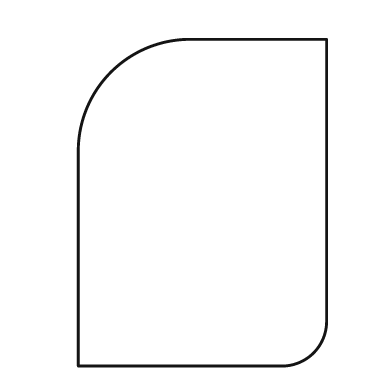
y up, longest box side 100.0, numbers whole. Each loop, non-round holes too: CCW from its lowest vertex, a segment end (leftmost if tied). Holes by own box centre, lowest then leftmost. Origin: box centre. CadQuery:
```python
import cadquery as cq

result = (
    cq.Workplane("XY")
    .moveTo(-38.0, -50.0)
    .lineTo(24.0, -50.0)
    .threePointArc((34.0, -46.0), (38.0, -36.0))
    .lineTo(38.0, 50.0)
    .lineTo(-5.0, 50.0)
    .threePointArc((-28.0, 40.0), (-38.0, 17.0))
    .close()
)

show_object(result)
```